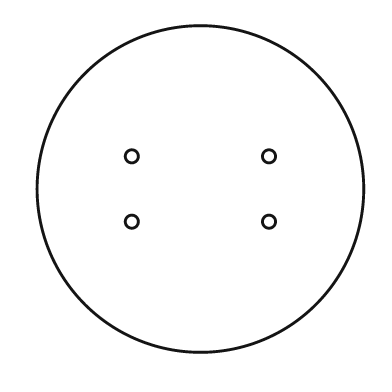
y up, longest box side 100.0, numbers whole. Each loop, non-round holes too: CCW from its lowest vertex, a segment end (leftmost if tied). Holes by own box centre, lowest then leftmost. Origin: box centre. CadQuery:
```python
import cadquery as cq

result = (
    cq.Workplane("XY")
    .moveTo(0.0, 0.0)
    .circle(50.0)
    .moveTo(-21.0, -10.0)
    .circle(2.0)
    .moveTo(21.0, -10.0)
    .circle(2.0)
    .moveTo(-21.0, 10.0)
    .circle(2.0)
    .moveTo(21.0, 10.0)
    .circle(2.0)
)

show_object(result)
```